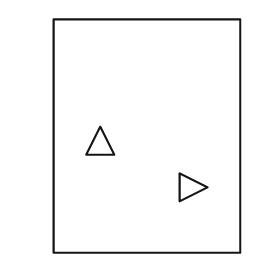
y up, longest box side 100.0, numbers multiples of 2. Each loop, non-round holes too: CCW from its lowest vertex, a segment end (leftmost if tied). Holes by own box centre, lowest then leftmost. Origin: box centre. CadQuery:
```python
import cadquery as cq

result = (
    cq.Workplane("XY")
    .moveTo(-40.0, -50.0)
    .lineTo(40.0, -50.0)
    .lineTo(40.0, 50.0)
    .lineTo(-40.0, 50.0)
    .close()
    .moveTo(14.0, -28.0)
    .lineTo(26.0, -22.0)
    .lineTo(14.0, -16.0)
    .close()
    .moveTo(-26.0, -8.0)
    .lineTo(-14.0, -8.0)
    .lineTo(-20.0, 4.0)
    .close()
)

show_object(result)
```